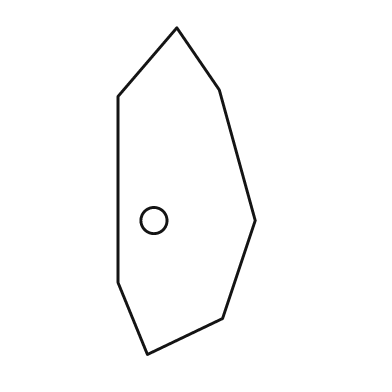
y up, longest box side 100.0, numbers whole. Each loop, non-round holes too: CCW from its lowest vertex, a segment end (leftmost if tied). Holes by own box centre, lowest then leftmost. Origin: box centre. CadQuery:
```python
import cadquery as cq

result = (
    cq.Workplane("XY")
    .moveTo(-12.0, -50.0)
    .lineTo(11.0, -39.0)
    .lineTo(21.0, -9.0)
    .lineTo(10.0, 31.0)
    .lineTo(-3.0, 50.0)
    .lineTo(-21.0, 29.0)
    .lineTo(-21.0, -28.0)
    .close()
    .moveTo(-10.0, -9.0)
    .circle(4.0)
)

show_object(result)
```